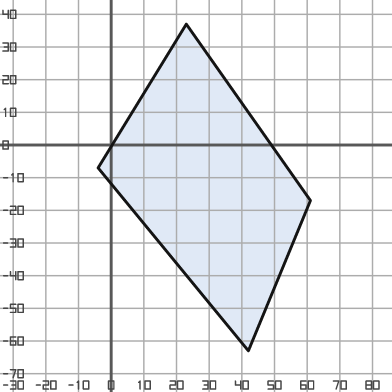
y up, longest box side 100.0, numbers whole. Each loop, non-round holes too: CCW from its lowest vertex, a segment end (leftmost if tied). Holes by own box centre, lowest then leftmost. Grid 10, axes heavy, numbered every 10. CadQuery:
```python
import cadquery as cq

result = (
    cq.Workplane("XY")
    .moveTo(42.0, -63.0)
    .lineTo(61.0, -17.0)
    .lineTo(23.0, 37.0)
    .lineTo(-4.0, -7.0)
    .close()
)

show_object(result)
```